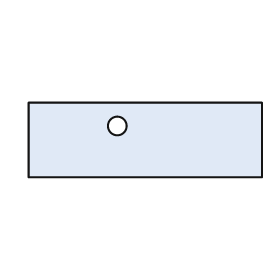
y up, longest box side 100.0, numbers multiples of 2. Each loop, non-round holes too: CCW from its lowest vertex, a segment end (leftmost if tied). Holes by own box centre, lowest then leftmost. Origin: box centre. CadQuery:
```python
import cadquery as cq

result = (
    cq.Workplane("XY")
    .moveTo(-50.0, -16.0)
    .lineTo(50.0, -16.0)
    .lineTo(50.0, 16.0)
    .lineTo(-50.0, 16.0)
    .close()
    .moveTo(-12.0, 6.0)
    .circle(4.0)
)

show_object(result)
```